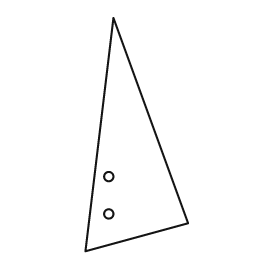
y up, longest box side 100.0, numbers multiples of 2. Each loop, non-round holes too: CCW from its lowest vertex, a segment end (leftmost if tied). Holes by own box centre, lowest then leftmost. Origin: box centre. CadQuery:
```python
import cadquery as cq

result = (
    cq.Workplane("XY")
    .moveTo(-22.0, -50.0)
    .lineTo(22.0, -38.0)
    .lineTo(-10.0, 50.0)
    .close()
    .moveTo(-12.0, -34.0)
    .circle(2.0)
    .moveTo(-12.0, -18.0)
    .circle(2.0)
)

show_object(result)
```